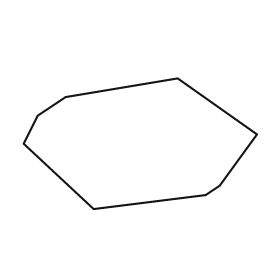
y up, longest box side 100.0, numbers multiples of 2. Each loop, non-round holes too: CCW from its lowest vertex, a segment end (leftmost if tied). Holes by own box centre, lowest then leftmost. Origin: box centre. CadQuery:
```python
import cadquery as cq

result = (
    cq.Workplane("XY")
    .moveTo(-20.0, -28.0)
    .lineTo(28.0, -22.0)
    .lineTo(34.0, -18.0)
    .lineTo(50.0, 4.0)
    .lineTo(16.0, 28.0)
    .lineTo(-32.0, 20.0)
    .lineTo(-44.0, 12.0)
    .lineTo(-50.0, 0.0)
    .close()
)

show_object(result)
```